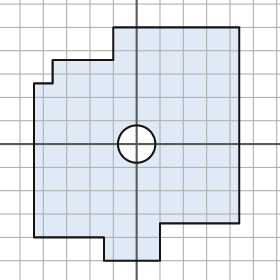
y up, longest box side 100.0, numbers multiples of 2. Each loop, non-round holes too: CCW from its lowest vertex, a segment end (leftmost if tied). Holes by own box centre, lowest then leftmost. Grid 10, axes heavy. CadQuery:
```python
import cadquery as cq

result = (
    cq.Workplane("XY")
    .moveTo(-14.0, -50.0)
    .lineTo(10.0, -50.0)
    .lineTo(10.0, -34.0)
    .lineTo(44.0, -34.0)
    .lineTo(44.0, 50.0)
    .lineTo(-10.0, 50.0)
    .lineTo(-10.0, 36.0)
    .lineTo(-36.0, 36.0)
    .lineTo(-36.0, 26.0)
    .lineTo(-44.0, 26.0)
    .lineTo(-44.0, -40.0)
    .lineTo(-14.0, -40.0)
    .close()
    .moveTo(0.0, 0.0)
    .circle(8.0)
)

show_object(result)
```